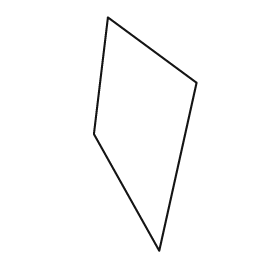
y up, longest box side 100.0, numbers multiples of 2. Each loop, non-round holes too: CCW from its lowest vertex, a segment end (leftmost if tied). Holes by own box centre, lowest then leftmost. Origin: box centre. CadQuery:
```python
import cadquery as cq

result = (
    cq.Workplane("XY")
    .moveTo(6.0, -50.0)
    .lineTo(22.0, 22.0)
    .lineTo(-16.0, 50.0)
    .lineTo(-22.0, 0.0)
    .close()
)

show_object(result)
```